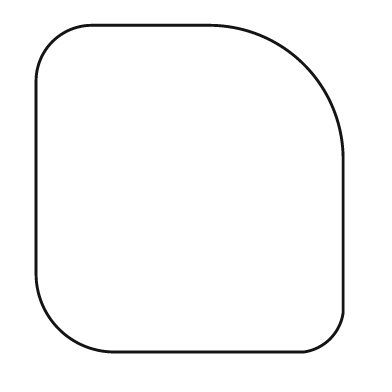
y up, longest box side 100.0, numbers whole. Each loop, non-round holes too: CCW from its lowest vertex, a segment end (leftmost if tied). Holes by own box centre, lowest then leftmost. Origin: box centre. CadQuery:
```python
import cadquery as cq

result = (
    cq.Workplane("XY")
    .moveTo(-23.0, -50.0)
    .lineTo(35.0, -50.0)
    .threePointArc((43.0, -46.0), (47.0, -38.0))
    .lineTo(47.0, 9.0)
    .threePointArc((35.0, 38.0), (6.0, 50.0))
    .lineTo(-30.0, 50.0)
    .threePointArc((-42.0, 45.0), (-47.0, 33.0))
    .lineTo(-47.0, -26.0)
    .threePointArc((-40.0, -43.0), (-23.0, -50.0))
    .close()
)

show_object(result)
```